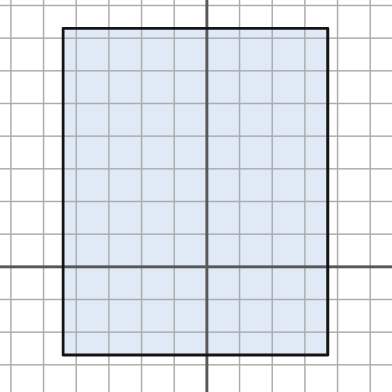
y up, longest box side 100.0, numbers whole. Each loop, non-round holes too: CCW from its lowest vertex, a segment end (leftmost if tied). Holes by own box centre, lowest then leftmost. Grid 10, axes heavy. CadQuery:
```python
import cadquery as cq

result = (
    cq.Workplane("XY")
    .moveTo(-44.0, -27.0)
    .lineTo(37.0, -27.0)
    .lineTo(37.0, 73.0)
    .lineTo(-44.0, 73.0)
    .close()
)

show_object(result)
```